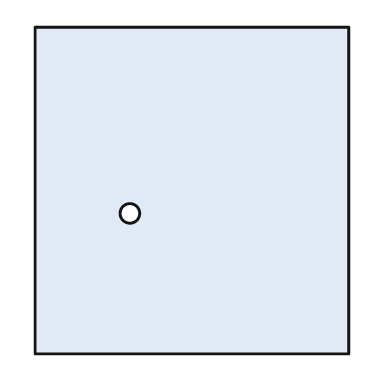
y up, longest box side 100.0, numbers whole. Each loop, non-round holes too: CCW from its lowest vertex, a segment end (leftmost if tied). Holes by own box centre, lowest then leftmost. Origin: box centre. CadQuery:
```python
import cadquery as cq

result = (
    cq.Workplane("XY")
    .moveTo(-48.0, -50.0)
    .lineTo(48.0, -50.0)
    .lineTo(48.0, 50.0)
    .lineTo(-48.0, 50.0)
    .close()
    .moveTo(-19.0, -7.0)
    .circle(3.0)
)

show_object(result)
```